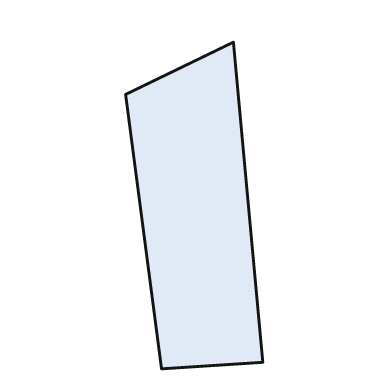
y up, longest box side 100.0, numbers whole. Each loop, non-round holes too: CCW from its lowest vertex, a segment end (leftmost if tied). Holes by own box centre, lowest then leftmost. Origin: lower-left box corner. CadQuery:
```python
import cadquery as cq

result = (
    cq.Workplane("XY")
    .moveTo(11.0, 0.0)
    .lineTo(42.0, 2.0)
    .lineTo(33.0, 100.0)
    .lineTo(0.0, 84.0)
    .close()
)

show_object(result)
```